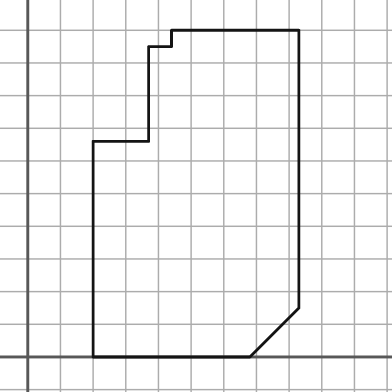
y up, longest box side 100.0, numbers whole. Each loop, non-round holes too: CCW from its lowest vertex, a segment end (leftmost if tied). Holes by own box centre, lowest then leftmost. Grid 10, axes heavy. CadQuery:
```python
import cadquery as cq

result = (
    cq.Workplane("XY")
    .moveTo(20.0, 0.0)
    .lineTo(68.0, 0.0)
    .lineTo(83.0, 15.0)
    .lineTo(83.0, 100.0)
    .lineTo(44.0, 100.0)
    .lineTo(44.0, 95.0)
    .lineTo(37.0, 95.0)
    .lineTo(37.0, 66.0)
    .lineTo(20.0, 66.0)
    .close()
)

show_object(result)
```